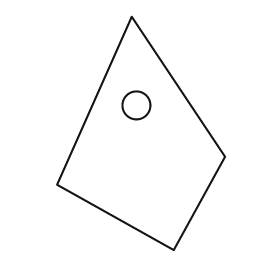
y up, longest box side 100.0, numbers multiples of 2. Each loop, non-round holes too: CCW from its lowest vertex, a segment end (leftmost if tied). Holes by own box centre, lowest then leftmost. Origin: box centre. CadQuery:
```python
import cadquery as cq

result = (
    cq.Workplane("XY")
    .moveTo(14.0, -50.0)
    .lineTo(36.0, -10.0)
    .lineTo(-4.0, 50.0)
    .lineTo(-36.0, -22.0)
    .close()
    .moveTo(-2.0, 12.0)
    .circle(6.0)
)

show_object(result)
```